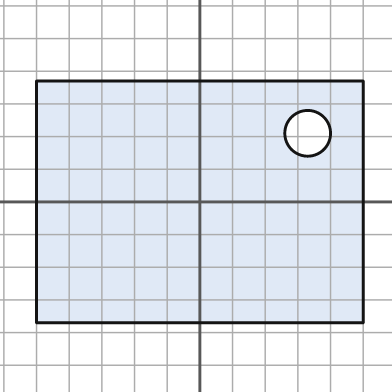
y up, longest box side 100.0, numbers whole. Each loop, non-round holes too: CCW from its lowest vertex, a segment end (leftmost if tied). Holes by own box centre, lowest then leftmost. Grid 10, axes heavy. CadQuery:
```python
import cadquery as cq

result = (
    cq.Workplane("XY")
    .moveTo(-50.0, -37.0)
    .lineTo(50.0, -37.0)
    .lineTo(50.0, 37.0)
    .lineTo(-50.0, 37.0)
    .close()
    .moveTo(33.0, 21.0)
    .circle(7.0)
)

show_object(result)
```